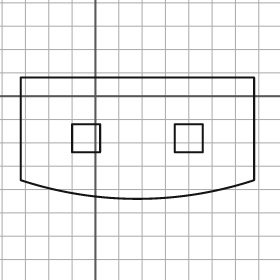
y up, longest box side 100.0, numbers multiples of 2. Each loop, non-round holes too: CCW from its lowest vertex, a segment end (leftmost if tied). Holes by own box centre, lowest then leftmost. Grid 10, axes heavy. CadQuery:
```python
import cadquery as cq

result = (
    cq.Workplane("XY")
    .moveTo(-32.0, -36.0)
    .threePointArc((18.0, -44.0), (68.0, -36.0))
    .lineTo(68.0, 8.0)
    .lineTo(-32.0, 8.0)
    .close()
    .moveTo(-10.0, -24.0)
    .lineTo(2.0, -24.0)
    .lineTo(2.0, -12.0)
    .lineTo(-10.0, -12.0)
    .close()
    .moveTo(34.0, -24.0)
    .lineTo(46.0, -24.0)
    .lineTo(46.0, -12.0)
    .lineTo(34.0, -12.0)
    .close()
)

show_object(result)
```